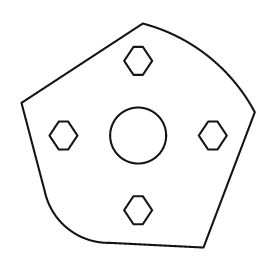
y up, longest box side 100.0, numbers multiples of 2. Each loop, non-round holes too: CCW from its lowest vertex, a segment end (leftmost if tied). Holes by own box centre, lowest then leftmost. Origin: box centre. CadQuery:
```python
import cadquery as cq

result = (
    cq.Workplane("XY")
    .moveTo(28.0, -48.0)
    .lineTo(50.0, 10.0)
    .threePointArc((30.0, 34.0), (2.0, 48.0))
    .lineTo(-50.0, 14.0)
    .lineTo(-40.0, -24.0)
    .threePointArc((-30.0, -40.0), (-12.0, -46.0))
    .close()
    .moveTo(-2.0, -38.0)
    .lineTo(2.0, -38.0)
    .lineTo(6.0, -32.0)
    .lineTo(2.0, -26.0)
    .lineTo(-2.0, -26.0)
    .lineTo(-6.0, -32.0)
    .close()
    .moveTo(-34.0, -6.0)
    .lineTo(-30.0, -6.0)
    .lineTo(-26.0, 0.0)
    .lineTo(-30.0, 6.0)
    .lineTo(-34.0, 6.0)
    .lineTo(-38.0, 0.0)
    .close()
    .moveTo(0.0, 0.0)
    .circle(12.0)
    .moveTo(30.0, -6.0)
    .lineTo(34.0, -6.0)
    .lineTo(38.0, 0.0)
    .lineTo(34.0, 6.0)
    .lineTo(30.0, 6.0)
    .lineTo(26.0, 0.0)
    .close()
    .moveTo(-2.0, 26.0)
    .lineTo(2.0, 26.0)
    .lineTo(6.0, 32.0)
    .lineTo(2.0, 38.0)
    .lineTo(-2.0, 38.0)
    .lineTo(-6.0, 32.0)
    .close()
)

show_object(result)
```